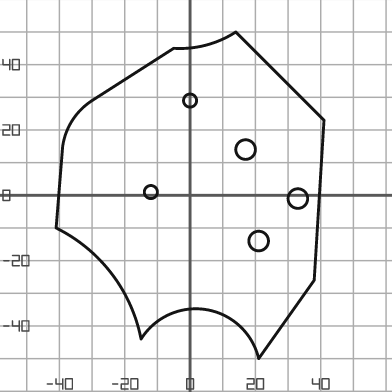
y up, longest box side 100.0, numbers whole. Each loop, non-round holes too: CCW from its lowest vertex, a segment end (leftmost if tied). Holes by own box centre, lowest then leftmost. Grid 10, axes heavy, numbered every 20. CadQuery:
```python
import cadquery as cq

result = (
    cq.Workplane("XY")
    .moveTo(21.0, -50.0)
    .lineTo(38.0, -26.0)
    .lineTo(41.0, 23.0)
    .lineTo(14.0, 50.0)
    .threePointArc((5.0, 46.0), (-5.0, 45.0))
    .lineTo(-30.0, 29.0)
    .threePointArc((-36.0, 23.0), (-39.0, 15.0))
    .lineTo(-41.0, -10.0)
    .threePointArc((-24.0, -24.0), (-15.0, -44.0))
    .threePointArc((5.0, -35.0), (21.0, -50.0))
    .close()
    .moveTo(21.0, -14.0)
    .circle(3.0)
    .moveTo(33.0, -1.0)
    .circle(3.0)
    .moveTo(-12.0, 1.0)
    .circle(2.0)
    .moveTo(17.0, 14.0)
    .circle(3.0)
    .moveTo(0.0, 29.0)
    .circle(2.0)
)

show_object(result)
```